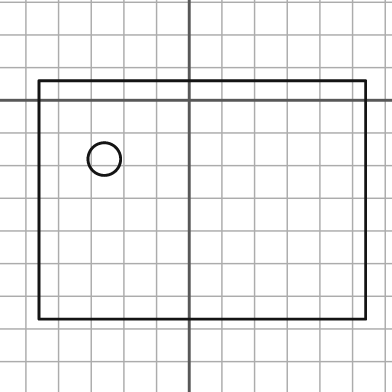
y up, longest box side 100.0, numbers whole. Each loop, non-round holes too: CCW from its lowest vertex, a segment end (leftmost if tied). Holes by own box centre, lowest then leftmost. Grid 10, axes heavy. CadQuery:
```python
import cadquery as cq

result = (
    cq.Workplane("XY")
    .moveTo(-46.0, -67.0)
    .lineTo(54.0, -67.0)
    .lineTo(54.0, 6.0)
    .lineTo(-46.0, 6.0)
    .close()
    .moveTo(-26.0, -18.0)
    .circle(5.0)
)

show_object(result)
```